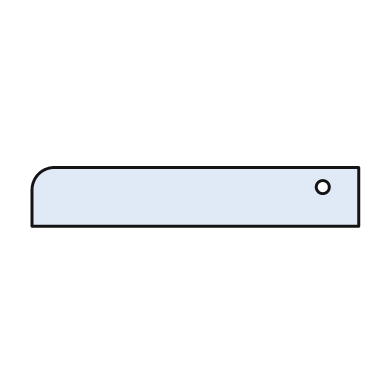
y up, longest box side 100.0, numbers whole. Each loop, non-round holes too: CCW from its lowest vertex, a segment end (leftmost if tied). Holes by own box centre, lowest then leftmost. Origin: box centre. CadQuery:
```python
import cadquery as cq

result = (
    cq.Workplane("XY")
    .moveTo(-50.0, -9.0)
    .lineTo(50.0, -9.0)
    .lineTo(50.0, 9.0)
    .lineTo(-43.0, 9.0)
    .threePointArc((-48.0, 7.0), (-50.0, 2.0))
    .close()
    .moveTo(39.0, 3.0)
    .circle(2.0)
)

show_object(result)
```